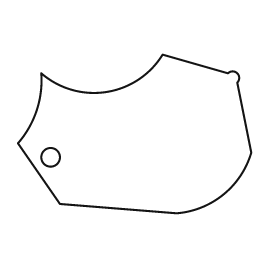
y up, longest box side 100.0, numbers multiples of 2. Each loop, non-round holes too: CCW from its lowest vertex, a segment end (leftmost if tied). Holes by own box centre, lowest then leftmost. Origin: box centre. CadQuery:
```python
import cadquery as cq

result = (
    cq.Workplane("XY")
    .moveTo(18.0, -34.0)
    .threePointArc((38.0, -26.0), (50.0, -8.0))
    .lineTo(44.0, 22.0)
    .threePointArc((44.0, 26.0), (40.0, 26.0))
    .lineTo(12.0, 34.0)
    .threePointArc((-12.0, 18.0), (-40.0, 26.0))
    .threePointArc((-42.0, 10.0), (-50.0, -4.0))
    .lineTo(-32.0, -30.0)
    .close()
    .moveTo(-36.0, -10.0)
    .circle(4.0)
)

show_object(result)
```